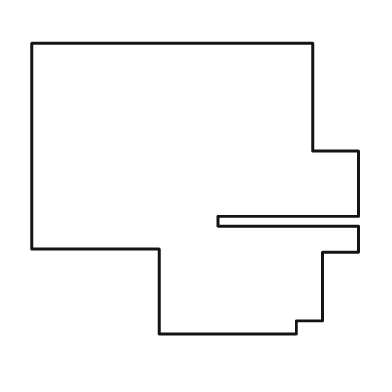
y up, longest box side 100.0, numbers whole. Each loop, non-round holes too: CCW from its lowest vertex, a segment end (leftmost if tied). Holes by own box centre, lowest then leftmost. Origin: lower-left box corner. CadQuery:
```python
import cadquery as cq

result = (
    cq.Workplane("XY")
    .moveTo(39.0, 0.0)
    .lineTo(81.0, 0.0)
    .lineTo(81.0, 4.0)
    .lineTo(89.0, 4.0)
    .lineTo(89.0, 25.0)
    .lineTo(100.0, 25.0)
    .lineTo(100.0, 33.0)
    .lineTo(57.0, 33.0)
    .lineTo(57.0, 36.0)
    .lineTo(100.0, 36.0)
    .lineTo(100.0, 56.0)
    .lineTo(86.0, 56.0)
    .lineTo(86.0, 89.0)
    .lineTo(0.0, 89.0)
    .lineTo(0.0, 26.0)
    .lineTo(39.0, 26.0)
    .close()
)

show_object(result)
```